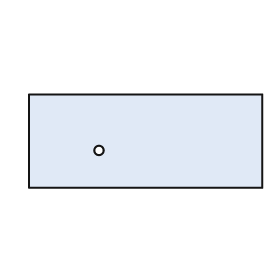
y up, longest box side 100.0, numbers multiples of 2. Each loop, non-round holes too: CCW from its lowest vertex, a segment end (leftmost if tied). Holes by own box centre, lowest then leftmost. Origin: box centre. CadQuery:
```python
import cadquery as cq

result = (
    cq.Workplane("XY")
    .moveTo(-50.0, -20.0)
    .lineTo(50.0, -20.0)
    .lineTo(50.0, 20.0)
    .lineTo(-50.0, 20.0)
    .close()
    .moveTo(-20.0, -4.0)
    .circle(2.0)
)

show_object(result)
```